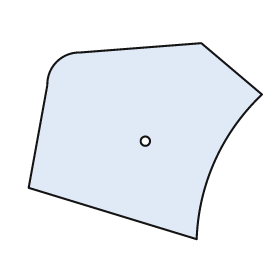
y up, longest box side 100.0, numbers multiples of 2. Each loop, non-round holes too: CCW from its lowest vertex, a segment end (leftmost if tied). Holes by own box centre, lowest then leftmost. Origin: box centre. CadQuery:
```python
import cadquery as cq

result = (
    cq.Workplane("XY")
    .moveTo(22.0, -42.0)
    .threePointArc((30.0, -8.0), (50.0, 20.0))
    .lineTo(24.0, 42.0)
    .lineTo(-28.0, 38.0)
    .threePointArc((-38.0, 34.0), (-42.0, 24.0))
    .lineTo(-50.0, -20.0)
    .close()
    .moveTo(0.0, 0.0)
    .circle(2.0)
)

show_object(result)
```